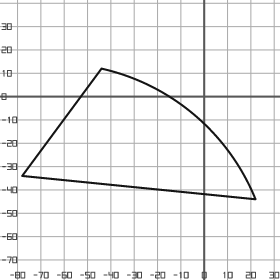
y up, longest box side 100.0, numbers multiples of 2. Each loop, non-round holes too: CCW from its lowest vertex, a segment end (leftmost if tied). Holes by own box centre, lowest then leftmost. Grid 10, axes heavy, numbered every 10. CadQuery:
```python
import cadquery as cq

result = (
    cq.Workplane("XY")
    .moveTo(22.0, -44.0)
    .threePointArc((-4.0, -8.0), (-44.0, 12.0))
    .lineTo(-78.0, -34.0)
    .close()
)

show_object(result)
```